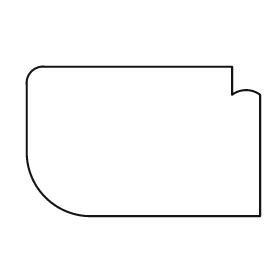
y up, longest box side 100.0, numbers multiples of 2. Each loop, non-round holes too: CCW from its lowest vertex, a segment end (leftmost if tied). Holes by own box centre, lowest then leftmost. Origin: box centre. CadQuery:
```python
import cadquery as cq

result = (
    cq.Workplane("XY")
    .moveTo(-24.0, -32.0)
    .lineTo(50.0, -32.0)
    .lineTo(50.0, 20.0)
    .threePointArc((44.0, 22.0), (38.0, 20.0))
    .lineTo(38.0, 32.0)
    .lineTo(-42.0, 32.0)
    .threePointArc((-48.0, 30.0), (-50.0, 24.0))
    .lineTo(-50.0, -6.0)
    .threePointArc((-42.0, -24.0), (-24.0, -32.0))
    .close()
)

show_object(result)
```